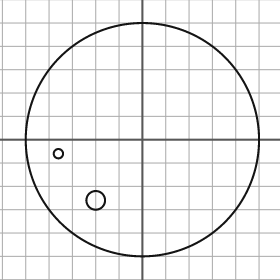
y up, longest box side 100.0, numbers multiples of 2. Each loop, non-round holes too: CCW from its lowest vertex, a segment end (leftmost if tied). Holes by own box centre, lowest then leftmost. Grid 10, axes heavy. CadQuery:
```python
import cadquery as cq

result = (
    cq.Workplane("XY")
    .moveTo(0.0, 0.0)
    .circle(50.0)
    .moveTo(-20.0, -26.0)
    .circle(4.0)
    .moveTo(-36.0, -6.0)
    .circle(2.0)
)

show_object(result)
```